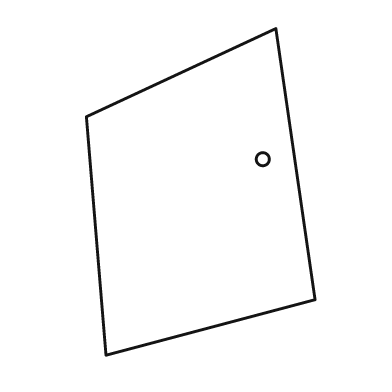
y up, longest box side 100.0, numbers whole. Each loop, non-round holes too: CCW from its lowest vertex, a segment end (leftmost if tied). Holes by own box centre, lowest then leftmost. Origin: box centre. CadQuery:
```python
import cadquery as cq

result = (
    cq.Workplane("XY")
    .moveTo(-29.0, -50.0)
    .lineTo(35.0, -33.0)
    .lineTo(23.0, 50.0)
    .lineTo(-35.0, 23.0)
    .close()
    .moveTo(19.0, 10.0)
    .circle(2.0)
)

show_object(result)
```